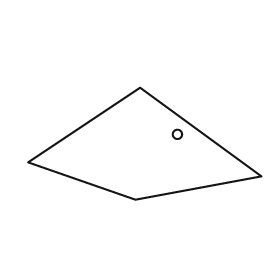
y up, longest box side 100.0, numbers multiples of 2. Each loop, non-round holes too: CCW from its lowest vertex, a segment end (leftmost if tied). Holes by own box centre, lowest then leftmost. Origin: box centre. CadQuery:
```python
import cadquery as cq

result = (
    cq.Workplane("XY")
    .moveTo(-4.0, -24.0)
    .lineTo(50.0, -14.0)
    .lineTo(-2.0, 24.0)
    .lineTo(-50.0, -8.0)
    .close()
    .moveTo(14.0, 4.0)
    .circle(2.0)
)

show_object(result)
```